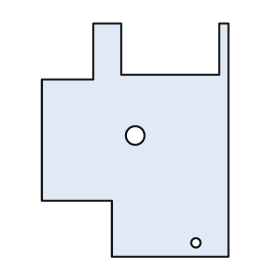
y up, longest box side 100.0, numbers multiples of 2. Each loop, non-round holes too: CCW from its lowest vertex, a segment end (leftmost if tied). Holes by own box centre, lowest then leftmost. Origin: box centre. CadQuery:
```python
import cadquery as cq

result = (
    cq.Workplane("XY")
    .moveTo(-10.0, -50.0)
    .lineTo(40.0, -50.0)
    .lineTo(40.0, 50.0)
    .lineTo(36.0, 50.0)
    .lineTo(36.0, 28.0)
    .lineTo(-6.0, 28.0)
    .lineTo(-6.0, 50.0)
    .lineTo(-18.0, 50.0)
    .lineTo(-18.0, 26.0)
    .lineTo(-40.0, 26.0)
    .lineTo(-40.0, -26.0)
    .lineTo(-10.0, -26.0)
    .close()
    .moveTo(26.0, -44.0)
    .circle(2.0)
    .moveTo(0.0, 2.0)
    .circle(4.0)
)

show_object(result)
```